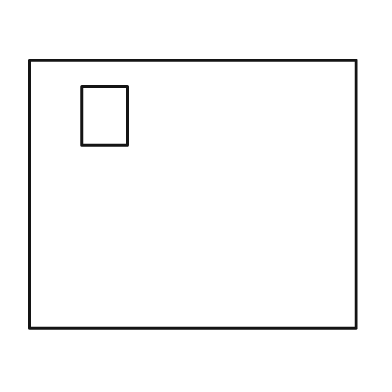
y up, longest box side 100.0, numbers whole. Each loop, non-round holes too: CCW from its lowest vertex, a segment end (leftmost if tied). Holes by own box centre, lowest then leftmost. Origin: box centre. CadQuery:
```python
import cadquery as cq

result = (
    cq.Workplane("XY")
    .moveTo(-50.0, -41.0)
    .lineTo(50.0, -41.0)
    .lineTo(50.0, 41.0)
    .lineTo(-50.0, 41.0)
    .close()
    .moveTo(-34.0, 15.0)
    .lineTo(-20.0, 15.0)
    .lineTo(-20.0, 33.0)
    .lineTo(-34.0, 33.0)
    .close()
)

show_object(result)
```